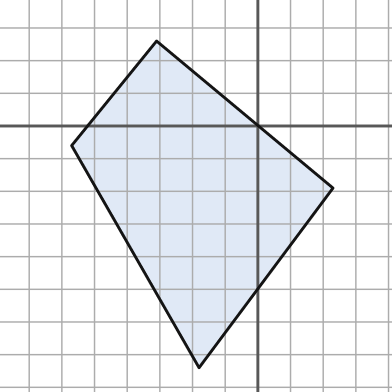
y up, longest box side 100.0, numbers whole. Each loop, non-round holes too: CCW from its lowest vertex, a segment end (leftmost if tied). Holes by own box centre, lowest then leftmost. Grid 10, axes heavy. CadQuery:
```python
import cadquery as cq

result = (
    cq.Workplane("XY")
    .moveTo(-18.0, -74.0)
    .lineTo(23.0, -19.0)
    .lineTo(-31.0, 26.0)
    .lineTo(-57.0, -6.0)
    .close()
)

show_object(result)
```